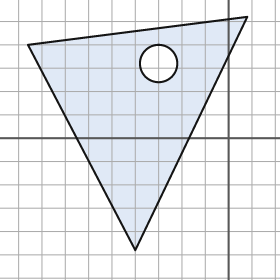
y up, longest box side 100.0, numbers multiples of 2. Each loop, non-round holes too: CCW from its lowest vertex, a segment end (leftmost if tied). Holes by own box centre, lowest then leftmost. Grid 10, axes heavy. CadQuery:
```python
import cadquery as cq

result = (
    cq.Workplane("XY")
    .moveTo(-40.0, -48.0)
    .lineTo(8.0, 52.0)
    .lineTo(-86.0, 40.0)
    .close()
    .moveTo(-30.0, 32.0)
    .circle(8.0)
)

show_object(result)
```